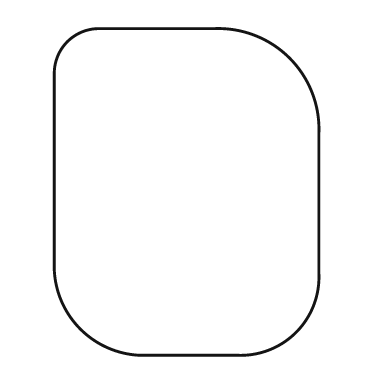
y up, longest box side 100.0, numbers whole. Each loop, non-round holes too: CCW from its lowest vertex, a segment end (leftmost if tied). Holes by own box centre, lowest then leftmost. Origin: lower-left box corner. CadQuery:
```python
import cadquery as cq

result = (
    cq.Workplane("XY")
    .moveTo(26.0, 0.0)
    .lineTo(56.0, 0.0)
    .threePointArc((74.0, 7.0), (81.0, 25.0))
    .lineTo(81.0, 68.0)
    .threePointArc((72.0, 91.0), (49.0, 100.0))
    .lineTo(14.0, 100.0)
    .threePointArc((4.0, 96.0), (0.0, 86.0))
    .lineTo(0.0, 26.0)
    .threePointArc((8.0, 8.0), (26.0, 0.0))
    .close()
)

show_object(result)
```